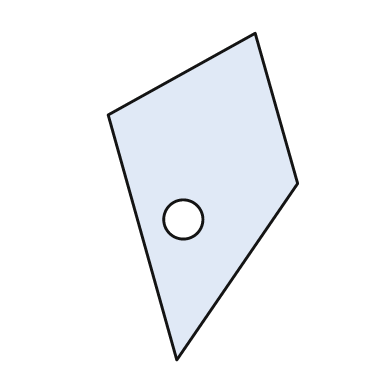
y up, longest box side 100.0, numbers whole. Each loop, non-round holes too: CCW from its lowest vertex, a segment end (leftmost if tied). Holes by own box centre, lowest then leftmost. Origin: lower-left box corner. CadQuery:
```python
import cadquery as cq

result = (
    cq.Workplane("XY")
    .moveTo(21.0, 0.0)
    .lineTo(58.0, 54.0)
    .lineTo(45.0, 100.0)
    .lineTo(0.0, 75.0)
    .close()
    .moveTo(23.0, 43.0)
    .circle(6.0)
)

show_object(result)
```